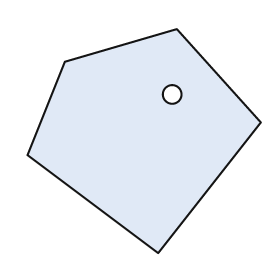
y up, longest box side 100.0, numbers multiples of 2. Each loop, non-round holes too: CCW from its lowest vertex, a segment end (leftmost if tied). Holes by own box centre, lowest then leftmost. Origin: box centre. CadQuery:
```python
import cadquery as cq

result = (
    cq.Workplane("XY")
    .moveTo(6.0, -48.0)
    .lineTo(50.0, 8.0)
    .lineTo(14.0, 48.0)
    .lineTo(-34.0, 34.0)
    .lineTo(-50.0, -6.0)
    .close()
    .moveTo(12.0, 20.0)
    .circle(4.0)
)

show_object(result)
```